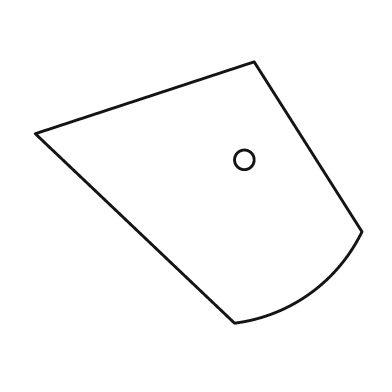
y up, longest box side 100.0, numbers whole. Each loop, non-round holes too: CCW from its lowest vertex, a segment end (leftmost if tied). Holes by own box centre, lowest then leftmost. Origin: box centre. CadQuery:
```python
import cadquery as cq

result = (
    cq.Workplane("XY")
    .moveTo(11.0, -40.0)
    .threePointArc((34.0, -31.0), (50.0, -12.0))
    .lineTo(17.0, 40.0)
    .lineTo(-50.0, 18.0)
    .close()
    .moveTo(14.0, 10.0)
    .circle(3.0)
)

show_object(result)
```